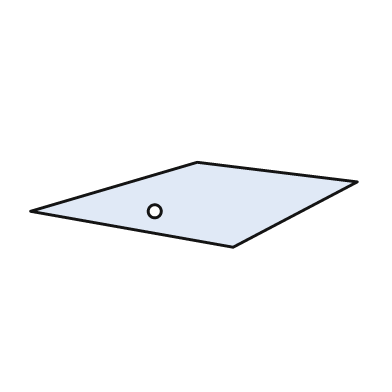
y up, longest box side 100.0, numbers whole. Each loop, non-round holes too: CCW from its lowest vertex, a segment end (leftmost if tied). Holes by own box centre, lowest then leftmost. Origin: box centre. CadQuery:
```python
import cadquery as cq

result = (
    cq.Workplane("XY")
    .moveTo(12.0, -13.0)
    .lineTo(50.0, 7.0)
    .lineTo(1.0, 13.0)
    .lineTo(-50.0, -2.0)
    .close()
    .moveTo(-12.0, -2.0)
    .circle(2.0)
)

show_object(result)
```